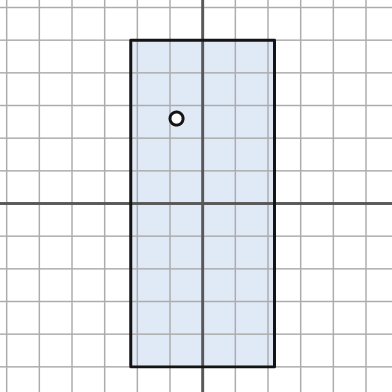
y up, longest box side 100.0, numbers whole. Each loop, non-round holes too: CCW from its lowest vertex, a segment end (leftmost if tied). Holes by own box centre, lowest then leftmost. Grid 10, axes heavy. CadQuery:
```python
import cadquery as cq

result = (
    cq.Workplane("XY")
    .moveTo(-22.0, -50.0)
    .lineTo(22.0, -50.0)
    .lineTo(22.0, 50.0)
    .lineTo(-22.0, 50.0)
    .close()
    .moveTo(-8.0, 26.0)
    .circle(2.0)
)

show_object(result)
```